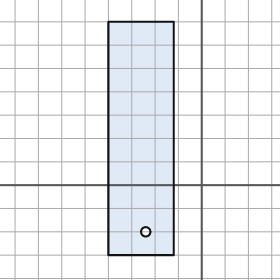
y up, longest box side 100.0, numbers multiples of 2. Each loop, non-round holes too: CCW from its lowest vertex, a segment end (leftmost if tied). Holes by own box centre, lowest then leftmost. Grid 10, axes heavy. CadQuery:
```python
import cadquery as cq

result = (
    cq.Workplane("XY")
    .moveTo(-40.0, -30.0)
    .lineTo(-12.0, -30.0)
    .lineTo(-12.0, 70.0)
    .lineTo(-40.0, 70.0)
    .close()
    .moveTo(-24.0, -20.0)
    .circle(2.0)
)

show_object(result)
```